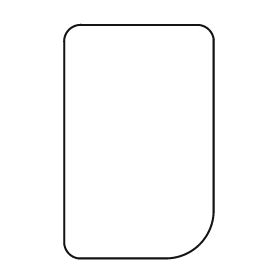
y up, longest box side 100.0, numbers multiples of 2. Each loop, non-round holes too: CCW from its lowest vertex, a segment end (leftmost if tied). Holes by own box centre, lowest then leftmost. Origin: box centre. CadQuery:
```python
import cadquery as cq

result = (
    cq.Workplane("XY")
    .moveTo(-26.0, -50.0)
    .lineTo(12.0, -50.0)
    .threePointArc((26.0, -44.0), (32.0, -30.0))
    .lineTo(32.0, 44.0)
    .threePointArc((30.0, 48.0), (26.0, 50.0))
    .lineTo(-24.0, 50.0)
    .threePointArc((-30.0, 48.0), (-32.0, 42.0))
    .lineTo(-32.0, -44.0)
    .threePointArc((-30.0, -48.0), (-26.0, -50.0))
    .close()
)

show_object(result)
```